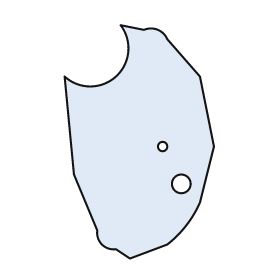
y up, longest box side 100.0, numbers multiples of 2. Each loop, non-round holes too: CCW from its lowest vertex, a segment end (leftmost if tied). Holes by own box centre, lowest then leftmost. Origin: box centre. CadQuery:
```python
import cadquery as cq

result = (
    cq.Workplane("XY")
    .moveTo(-4.0, -50.0)
    .lineTo(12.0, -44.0)
    .threePointArc((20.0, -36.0), (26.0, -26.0))
    .lineTo(32.0, -2.0)
    .lineTo(26.0, 28.0)
    .lineTo(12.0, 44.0)
    .threePointArc((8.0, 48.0), (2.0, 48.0))
    .lineTo(-8.0, 50.0)
    .threePointArc((-10.0, 28.0), (-32.0, 28.0))
    .lineTo(-28.0, -14.0)
    .lineTo(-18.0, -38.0)
    .threePointArc((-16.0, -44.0), (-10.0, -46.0))
    .close()
    .moveTo(18.0, -18.0)
    .circle(4.0)
    .moveTo(10.0, -2.0)
    .circle(2.0)
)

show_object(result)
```